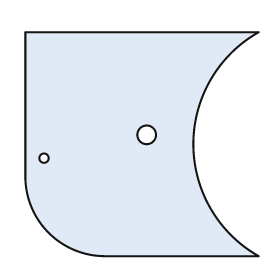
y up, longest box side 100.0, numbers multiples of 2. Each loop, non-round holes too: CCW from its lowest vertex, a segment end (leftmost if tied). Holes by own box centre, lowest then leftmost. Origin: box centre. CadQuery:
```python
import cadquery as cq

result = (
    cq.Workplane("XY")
    .moveTo(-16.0, -48.0)
    .lineTo(50.0, -48.0)
    .threePointArc((22.0, 0.0), (50.0, 48.0))
    .lineTo(-50.0, 48.0)
    .lineTo(-50.0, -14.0)
    .threePointArc((-40.0, -38.0), (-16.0, -48.0))
    .close()
    .moveTo(-42.0, -6.0)
    .circle(2.0)
    .moveTo(2.0, 4.0)
    .circle(4.0)
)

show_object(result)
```